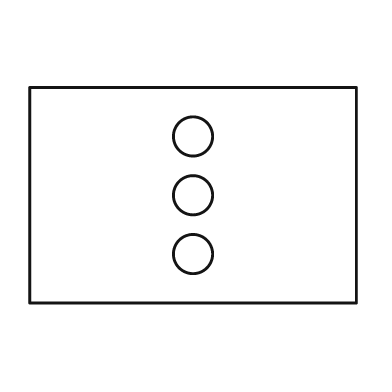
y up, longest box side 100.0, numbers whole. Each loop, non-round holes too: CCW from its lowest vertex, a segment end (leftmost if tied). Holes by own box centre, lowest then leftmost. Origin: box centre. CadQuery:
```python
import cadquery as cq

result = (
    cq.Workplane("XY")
    .moveTo(-50.0, -33.0)
    .lineTo(50.0, -33.0)
    .lineTo(50.0, 33.0)
    .lineTo(-50.0, 33.0)
    .close()
    .moveTo(0.0, -18.0)
    .circle(6.0)
    .moveTo(0.0, 0.0)
    .circle(6.0)
    .moveTo(0.0, 18.0)
    .circle(6.0)
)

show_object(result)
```